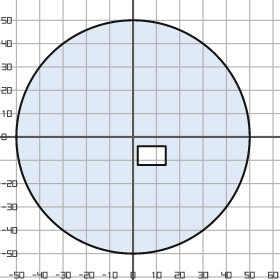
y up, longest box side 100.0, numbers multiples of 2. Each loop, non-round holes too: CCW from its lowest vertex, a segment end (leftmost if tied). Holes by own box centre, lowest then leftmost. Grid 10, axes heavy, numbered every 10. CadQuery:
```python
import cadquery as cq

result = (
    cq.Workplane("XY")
    .moveTo(0.0, 0.0)
    .circle(50.0)
    .moveTo(2.0, -12.0)
    .lineTo(14.0, -12.0)
    .lineTo(14.0, -4.0)
    .lineTo(2.0, -4.0)
    .close()
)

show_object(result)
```